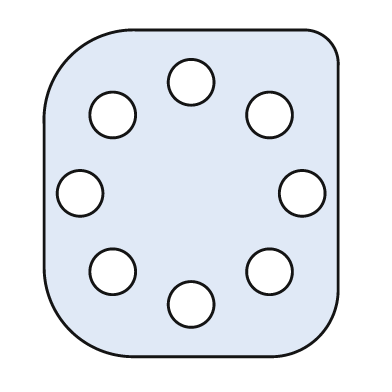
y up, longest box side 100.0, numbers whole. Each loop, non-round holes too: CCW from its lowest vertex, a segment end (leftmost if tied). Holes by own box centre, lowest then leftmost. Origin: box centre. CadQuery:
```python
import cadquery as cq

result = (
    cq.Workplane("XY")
    .moveTo(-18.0, -50.0)
    .lineTo(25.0, -50.0)
    .threePointArc((39.0, -44.0), (45.0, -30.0))
    .lineTo(45.0, 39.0)
    .threePointArc((42.0, 47.0), (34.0, 50.0))
    .lineTo(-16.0, 50.0)
    .threePointArc((-37.0, 42.0), (-45.0, 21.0))
    .lineTo(-45.0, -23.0)
    .threePointArc((-37.0, -42.0), (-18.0, -50.0))
    .close()
    .moveTo(0.0, -34.0)
    .circle(7.0)
    .moveTo(-24.0, -24.0)
    .circle(7.0)
    .moveTo(24.0, -24.0)
    .circle(7.0)
    .moveTo(-34.0, 0.0)
    .circle(7.0)
    .moveTo(34.0, 0.0)
    .circle(7.0)
    .moveTo(-24.0, 24.0)
    .circle(7.0)
    .moveTo(24.0, 24.0)
    .circle(7.0)
    .moveTo(0.0, 34.0)
    .circle(7.0)
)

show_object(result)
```